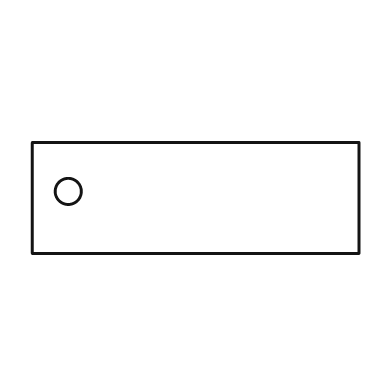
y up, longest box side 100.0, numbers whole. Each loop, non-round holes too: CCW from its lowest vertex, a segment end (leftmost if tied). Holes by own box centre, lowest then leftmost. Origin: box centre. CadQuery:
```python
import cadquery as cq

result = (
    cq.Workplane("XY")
    .moveTo(-50.0, -17.0)
    .lineTo(50.0, -17.0)
    .lineTo(50.0, 17.0)
    .lineTo(-50.0, 17.0)
    .close()
    .moveTo(-39.0, 2.0)
    .circle(4.0)
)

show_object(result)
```